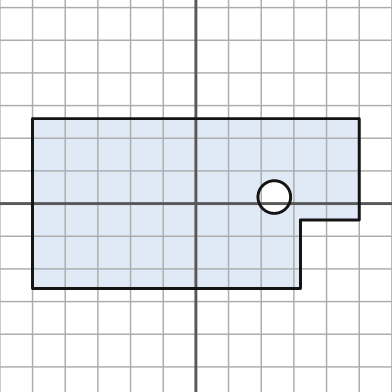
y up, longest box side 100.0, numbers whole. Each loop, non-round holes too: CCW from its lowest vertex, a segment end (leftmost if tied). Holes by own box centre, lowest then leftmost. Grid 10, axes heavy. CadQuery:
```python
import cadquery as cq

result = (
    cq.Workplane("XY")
    .moveTo(-50.0, -26.0)
    .lineTo(32.0, -26.0)
    .lineTo(32.0, -5.0)
    .lineTo(50.0, -5.0)
    .lineTo(50.0, 26.0)
    .lineTo(-50.0, 26.0)
    .close()
    .moveTo(24.0, 2.0)
    .circle(5.0)
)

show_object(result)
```